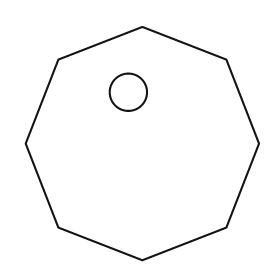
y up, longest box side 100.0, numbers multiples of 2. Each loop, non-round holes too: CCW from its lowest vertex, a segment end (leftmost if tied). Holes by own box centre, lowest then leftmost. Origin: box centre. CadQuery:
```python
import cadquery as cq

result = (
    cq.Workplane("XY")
    .moveTo(0.0, -50.0)
    .lineTo(36.0, -36.0)
    .lineTo(50.0, 0.0)
    .lineTo(36.0, 36.0)
    .lineTo(0.0, 50.0)
    .lineTo(-36.0, 36.0)
    .lineTo(-50.0, 0.0)
    .lineTo(-36.0, -36.0)
    .close()
    .moveTo(-6.0, 22.0)
    .circle(8.0)
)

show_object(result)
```